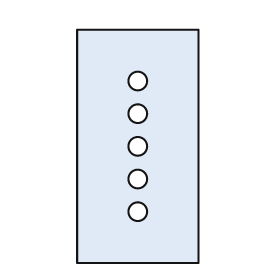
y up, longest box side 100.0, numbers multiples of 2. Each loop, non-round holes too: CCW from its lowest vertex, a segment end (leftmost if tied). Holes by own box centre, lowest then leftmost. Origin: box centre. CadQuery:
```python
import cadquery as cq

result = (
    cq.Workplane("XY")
    .moveTo(-26.0, -50.0)
    .lineTo(26.0, -50.0)
    .lineTo(26.0, 50.0)
    .lineTo(-26.0, 50.0)
    .close()
    .moveTo(0.0, -28.0)
    .circle(4.0)
    .moveTo(0.0, -14.0)
    .circle(4.0)
    .moveTo(0.0, 0.0)
    .circle(4.0)
    .moveTo(0.0, 14.0)
    .circle(4.0)
    .moveTo(0.0, 28.0)
    .circle(4.0)
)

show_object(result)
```